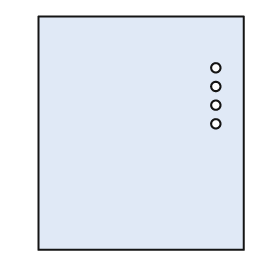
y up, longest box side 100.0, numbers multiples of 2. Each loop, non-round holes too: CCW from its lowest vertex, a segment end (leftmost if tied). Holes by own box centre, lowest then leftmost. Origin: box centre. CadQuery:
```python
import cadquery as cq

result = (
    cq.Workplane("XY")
    .moveTo(-44.0, -50.0)
    .lineTo(44.0, -50.0)
    .lineTo(44.0, 50.0)
    .lineTo(-44.0, 50.0)
    .close()
    .moveTo(32.0, 4.0)
    .circle(2.0)
    .moveTo(32.0, 12.0)
    .circle(2.0)
    .moveTo(32.0, 20.0)
    .circle(2.0)
    .moveTo(32.0, 28.0)
    .circle(2.0)
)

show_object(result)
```